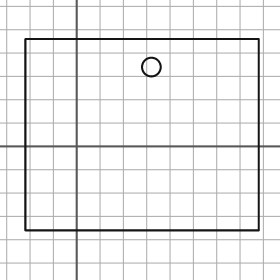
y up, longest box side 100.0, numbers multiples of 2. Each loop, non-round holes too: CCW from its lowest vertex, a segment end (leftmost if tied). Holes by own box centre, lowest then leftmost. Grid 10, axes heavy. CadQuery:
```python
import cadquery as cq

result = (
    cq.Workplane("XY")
    .moveTo(-22.0, -36.0)
    .lineTo(78.0, -36.0)
    .lineTo(78.0, 46.0)
    .lineTo(-22.0, 46.0)
    .close()
    .moveTo(32.0, 34.0)
    .circle(4.0)
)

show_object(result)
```